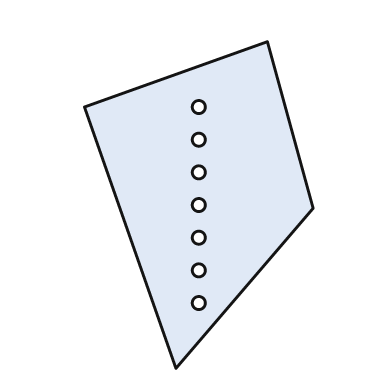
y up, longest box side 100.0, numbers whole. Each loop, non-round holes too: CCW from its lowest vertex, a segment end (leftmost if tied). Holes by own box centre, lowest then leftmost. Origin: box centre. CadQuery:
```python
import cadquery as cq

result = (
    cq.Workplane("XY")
    .moveTo(-7.0, -50.0)
    .lineTo(35.0, -1.0)
    .lineTo(21.0, 50.0)
    .lineTo(-35.0, 30.0)
    .close()
    .moveTo(0.0, -30.0)
    .circle(2.0)
    .moveTo(0.0, -20.0)
    .circle(2.0)
    .moveTo(0.0, -10.0)
    .circle(2.0)
    .moveTo(0.0, 0.0)
    .circle(2.0)
    .moveTo(0.0, 10.0)
    .circle(2.0)
    .moveTo(0.0, 20.0)
    .circle(2.0)
    .moveTo(0.0, 30.0)
    .circle(2.0)
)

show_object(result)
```